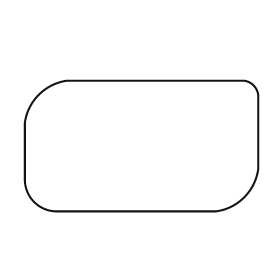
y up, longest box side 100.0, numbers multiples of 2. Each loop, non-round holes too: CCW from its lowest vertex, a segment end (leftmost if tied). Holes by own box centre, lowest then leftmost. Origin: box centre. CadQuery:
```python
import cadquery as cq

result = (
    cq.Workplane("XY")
    .moveTo(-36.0, -28.0)
    .lineTo(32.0, -28.0)
    .threePointArc((44.0, -22.0), (50.0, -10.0))
    .lineTo(50.0, 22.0)
    .threePointArc((48.0, 26.0), (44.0, 28.0))
    .lineTo(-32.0, 28.0)
    .threePointArc((-44.0, 22.0), (-50.0, 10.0))
    .lineTo(-50.0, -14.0)
    .threePointArc((-46.0, -24.0), (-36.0, -28.0))
    .close()
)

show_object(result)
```